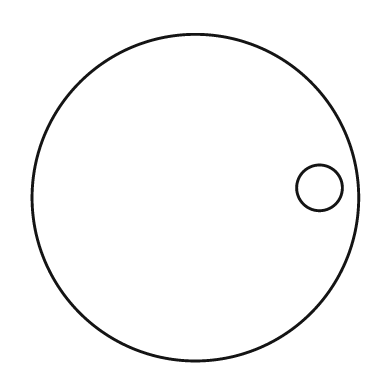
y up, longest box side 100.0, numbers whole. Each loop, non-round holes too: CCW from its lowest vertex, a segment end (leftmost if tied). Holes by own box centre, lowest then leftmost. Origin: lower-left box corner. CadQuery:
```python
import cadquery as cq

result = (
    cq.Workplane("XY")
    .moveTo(50.0, 50.0)
    .circle(50.0)
    .moveTo(88.0, 53.0)
    .circle(7.0)
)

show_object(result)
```